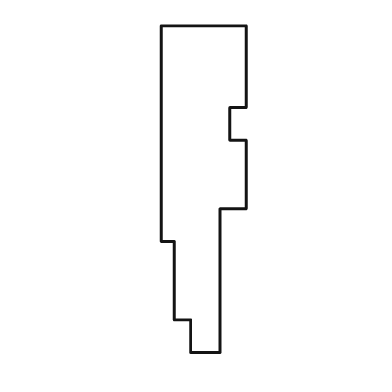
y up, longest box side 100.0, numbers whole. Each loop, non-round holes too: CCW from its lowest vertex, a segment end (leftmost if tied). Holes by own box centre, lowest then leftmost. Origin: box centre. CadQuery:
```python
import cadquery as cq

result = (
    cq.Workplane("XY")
    .moveTo(-4.0, -50.0)
    .lineTo(5.0, -50.0)
    .lineTo(5.0, -6.0)
    .lineTo(13.0, -6.0)
    .lineTo(13.0, 15.0)
    .lineTo(8.0, 15.0)
    .lineTo(8.0, 25.0)
    .lineTo(13.0, 25.0)
    .lineTo(13.0, 50.0)
    .lineTo(-13.0, 50.0)
    .lineTo(-13.0, -16.0)
    .lineTo(-9.0, -16.0)
    .lineTo(-9.0, -40.0)
    .lineTo(-4.0, -40.0)
    .close()
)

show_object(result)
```